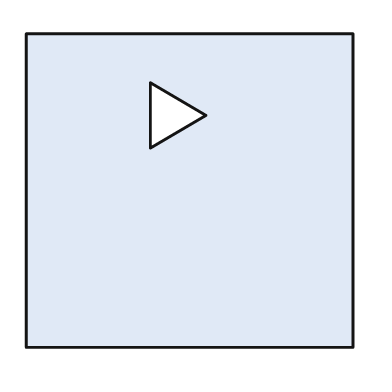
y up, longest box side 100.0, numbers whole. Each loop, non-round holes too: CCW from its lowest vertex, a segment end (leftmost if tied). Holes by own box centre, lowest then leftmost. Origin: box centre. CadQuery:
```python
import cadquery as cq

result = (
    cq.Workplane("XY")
    .moveTo(-50.0, -48.0)
    .lineTo(50.0, -48.0)
    .lineTo(50.0, 48.0)
    .lineTo(-50.0, 48.0)
    .close()
    .moveTo(-12.0, 13.0)
    .lineTo(5.0, 23.0)
    .lineTo(-12.0, 33.0)
    .close()
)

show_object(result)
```